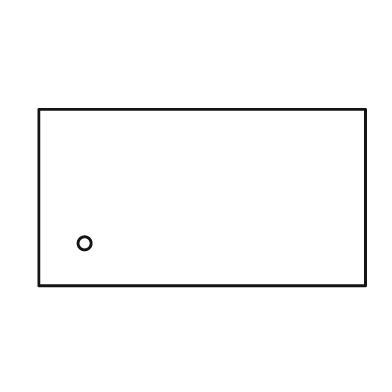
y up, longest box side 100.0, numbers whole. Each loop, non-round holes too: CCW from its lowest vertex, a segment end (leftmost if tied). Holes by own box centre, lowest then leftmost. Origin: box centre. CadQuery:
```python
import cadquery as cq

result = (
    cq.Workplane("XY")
    .moveTo(-50.0, -27.0)
    .lineTo(50.0, -27.0)
    .lineTo(50.0, 27.0)
    .lineTo(-50.0, 27.0)
    .close()
    .moveTo(-36.0, -14.0)
    .circle(2.0)
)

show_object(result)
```